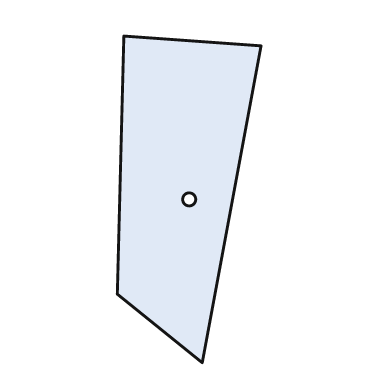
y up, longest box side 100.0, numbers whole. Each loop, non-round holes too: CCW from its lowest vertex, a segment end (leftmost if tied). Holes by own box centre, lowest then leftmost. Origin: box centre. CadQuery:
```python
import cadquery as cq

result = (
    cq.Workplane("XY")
    .moveTo(4.0, -50.0)
    .lineTo(22.0, 47.0)
    .lineTo(-20.0, 50.0)
    .lineTo(-22.0, -29.0)
    .close()
    .moveTo(0.0, 0.0)
    .circle(2.0)
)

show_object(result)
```